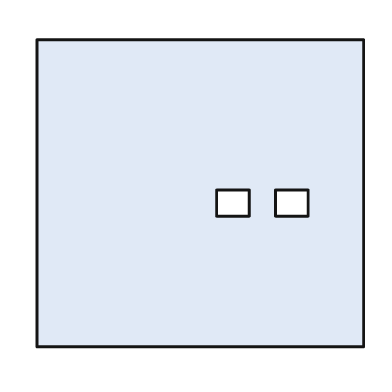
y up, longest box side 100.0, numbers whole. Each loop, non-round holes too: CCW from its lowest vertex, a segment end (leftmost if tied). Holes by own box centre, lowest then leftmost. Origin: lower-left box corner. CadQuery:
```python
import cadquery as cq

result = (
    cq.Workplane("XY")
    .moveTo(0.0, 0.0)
    .lineTo(100.0, 0.0)
    .lineTo(100.0, 94.0)
    .lineTo(0.0, 94.0)
    .close()
    .moveTo(55.0, 40.0)
    .lineTo(65.0, 40.0)
    .lineTo(65.0, 48.0)
    .lineTo(55.0, 48.0)
    .close()
    .moveTo(73.0, 40.0)
    .lineTo(83.0, 40.0)
    .lineTo(83.0, 48.0)
    .lineTo(73.0, 48.0)
    .close()
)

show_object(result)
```